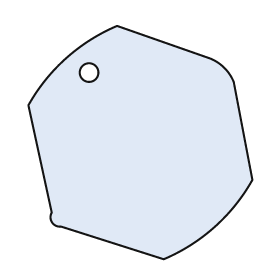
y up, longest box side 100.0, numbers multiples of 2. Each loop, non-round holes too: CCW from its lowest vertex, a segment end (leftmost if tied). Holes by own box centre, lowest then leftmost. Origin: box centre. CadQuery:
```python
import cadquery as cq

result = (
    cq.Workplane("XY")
    .moveTo(10.0, -50.0)
    .threePointArc((32.0, -36.0), (48.0, -16.0))
    .lineTo(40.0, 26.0)
    .threePointArc((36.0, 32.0), (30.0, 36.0))
    .lineTo(-10.0, 50.0)
    .threePointArc((-32.0, 36.0), (-48.0, 16.0))
    .lineTo(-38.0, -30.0)
    .threePointArc((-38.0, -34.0), (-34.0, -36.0))
    .close()
    .moveTo(-22.0, 30.0)
    .circle(4.0)
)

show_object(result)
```